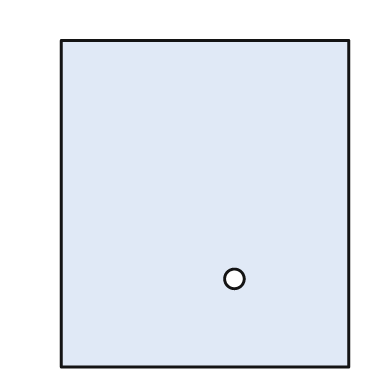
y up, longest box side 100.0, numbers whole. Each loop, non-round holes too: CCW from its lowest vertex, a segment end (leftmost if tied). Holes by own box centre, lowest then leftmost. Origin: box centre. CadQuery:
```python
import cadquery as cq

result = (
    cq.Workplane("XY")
    .moveTo(-44.0, -50.0)
    .lineTo(44.0, -50.0)
    .lineTo(44.0, 50.0)
    .lineTo(-44.0, 50.0)
    .close()
    .moveTo(9.0, -23.0)
    .circle(3.0)
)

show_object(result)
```